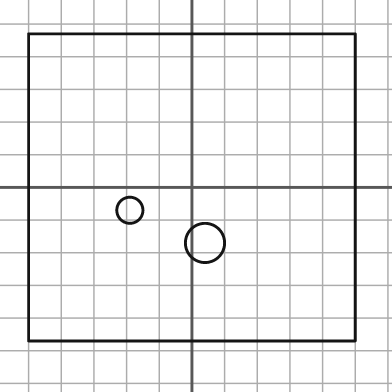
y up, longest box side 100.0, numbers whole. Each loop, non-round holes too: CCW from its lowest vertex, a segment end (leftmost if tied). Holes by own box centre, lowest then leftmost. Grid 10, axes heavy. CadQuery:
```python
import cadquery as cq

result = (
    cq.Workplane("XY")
    .moveTo(-50.0, -47.0)
    .lineTo(50.0, -47.0)
    .lineTo(50.0, 47.0)
    .lineTo(-50.0, 47.0)
    .close()
    .moveTo(4.0, -17.0)
    .circle(6.0)
    .moveTo(-19.0, -7.0)
    .circle(4.0)
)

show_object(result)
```